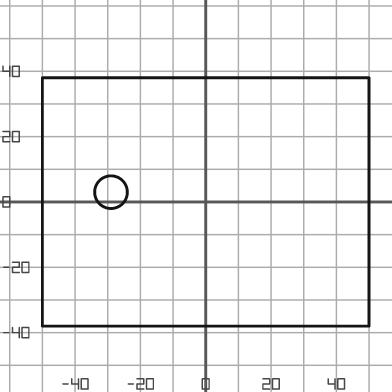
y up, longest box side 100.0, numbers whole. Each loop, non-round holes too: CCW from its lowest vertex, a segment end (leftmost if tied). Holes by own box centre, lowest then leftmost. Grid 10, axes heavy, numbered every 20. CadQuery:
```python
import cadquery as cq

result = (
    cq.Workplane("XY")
    .moveTo(-50.0, -38.0)
    .lineTo(50.0, -38.0)
    .lineTo(50.0, 38.0)
    .lineTo(-50.0, 38.0)
    .close()
    .moveTo(-29.0, 3.0)
    .circle(5.0)
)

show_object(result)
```